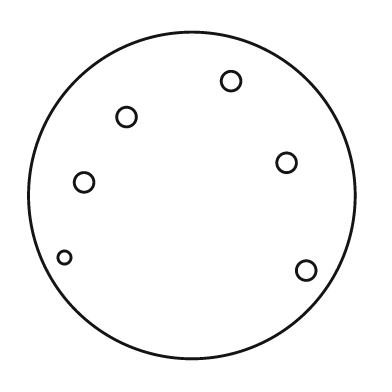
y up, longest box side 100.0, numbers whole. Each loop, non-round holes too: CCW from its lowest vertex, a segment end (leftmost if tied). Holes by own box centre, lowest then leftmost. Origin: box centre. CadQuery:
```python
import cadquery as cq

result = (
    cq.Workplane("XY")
    .moveTo(0.0, 0.0)
    .circle(50.0)
    .moveTo(35.0, -23.0)
    .circle(3.0)
    .moveTo(-39.0, -19.0)
    .circle(2.0)
    .moveTo(-33.0, 4.0)
    .circle(3.0)
    .moveTo(29.0, 10.0)
    .circle(3.0)
    .moveTo(-20.0, 24.0)
    .circle(3.0)
    .moveTo(12.0, 35.0)
    .circle(3.0)
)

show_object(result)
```